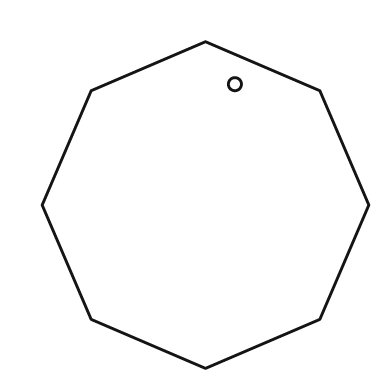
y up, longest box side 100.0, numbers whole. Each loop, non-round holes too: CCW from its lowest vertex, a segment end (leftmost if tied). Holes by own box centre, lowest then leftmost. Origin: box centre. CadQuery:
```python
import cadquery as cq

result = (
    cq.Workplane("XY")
    .moveTo(0.0, -50.0)
    .lineTo(35.0, -35.0)
    .lineTo(50.0, 0.0)
    .lineTo(35.0, 35.0)
    .lineTo(0.0, 50.0)
    .lineTo(-35.0, 35.0)
    .lineTo(-50.0, 0.0)
    .lineTo(-35.0, -35.0)
    .close()
    .moveTo(9.0, 37.0)
    .circle(2.0)
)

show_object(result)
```